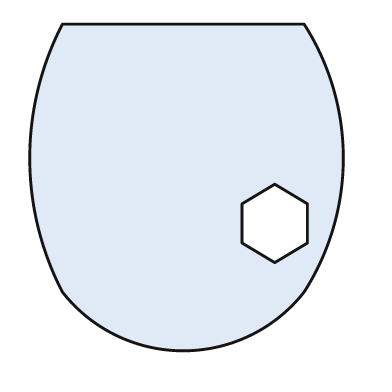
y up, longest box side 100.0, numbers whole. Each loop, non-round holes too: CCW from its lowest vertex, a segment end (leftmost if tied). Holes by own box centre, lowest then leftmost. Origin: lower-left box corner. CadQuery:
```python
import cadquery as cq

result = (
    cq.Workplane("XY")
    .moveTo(10.0, 18.0)
    .threePointArc((47.0, 0.0), (84.0, 18.0))
    .threePointArc((96.0, 59.0), (84.0, 100.0))
    .lineTo(10.0, 100.0)
    .threePointArc((0.0, 59.0), (10.0, 18.0))
    .close()
    .moveTo(75.0, 27.0)
    .lineTo(85.0, 33.0)
    .lineTo(85.0, 45.0)
    .lineTo(75.0, 51.0)
    .lineTo(65.0, 45.0)
    .lineTo(65.0, 33.0)
    .close()
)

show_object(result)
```